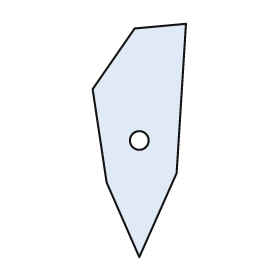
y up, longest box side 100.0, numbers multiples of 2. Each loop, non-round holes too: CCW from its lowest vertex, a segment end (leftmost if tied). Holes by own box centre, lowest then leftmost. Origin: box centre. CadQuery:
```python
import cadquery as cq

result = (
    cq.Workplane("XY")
    .moveTo(0.0, -50.0)
    .lineTo(16.0, -14.0)
    .lineTo(20.0, 50.0)
    .lineTo(-2.0, 48.0)
    .lineTo(-20.0, 22.0)
    .lineTo(-14.0, -18.0)
    .close()
    .moveTo(0.0, 0.0)
    .circle(4.0)
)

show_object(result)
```